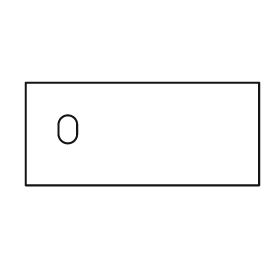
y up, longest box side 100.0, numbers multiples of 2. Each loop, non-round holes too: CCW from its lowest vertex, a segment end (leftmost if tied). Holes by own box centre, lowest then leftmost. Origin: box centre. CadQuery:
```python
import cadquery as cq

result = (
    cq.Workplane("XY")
    .moveTo(-50.0, -22.0)
    .lineTo(50.0, -22.0)
    .lineTo(50.0, 22.0)
    .lineTo(-50.0, 22.0)
    .close()
    .moveTo(-36.0, 0.0)
    .threePointArc((-32.0, -4.0), (-28.0, 0.0))
    .lineTo(-28.0, 4.0)
    .threePointArc((-32.0, 8.0), (-36.0, 4.0))
    .close()
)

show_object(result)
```